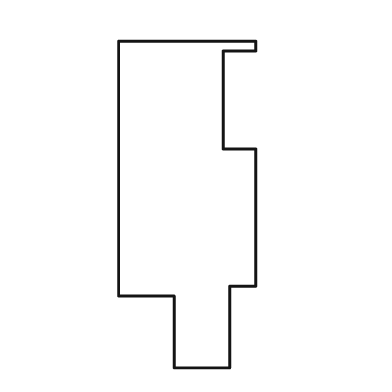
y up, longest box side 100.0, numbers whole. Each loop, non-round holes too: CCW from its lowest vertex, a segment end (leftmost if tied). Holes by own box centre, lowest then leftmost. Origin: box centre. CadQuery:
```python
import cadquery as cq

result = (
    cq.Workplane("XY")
    .moveTo(-4.0, -50.0)
    .lineTo(13.0, -50.0)
    .lineTo(13.0, -25.0)
    .lineTo(21.0, -25.0)
    .lineTo(21.0, 17.0)
    .lineTo(11.0, 17.0)
    .lineTo(11.0, 47.0)
    .lineTo(21.0, 47.0)
    .lineTo(21.0, 50.0)
    .lineTo(-21.0, 50.0)
    .lineTo(-21.0, -28.0)
    .lineTo(-4.0, -28.0)
    .close()
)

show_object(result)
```